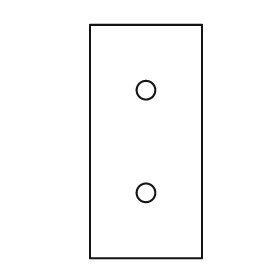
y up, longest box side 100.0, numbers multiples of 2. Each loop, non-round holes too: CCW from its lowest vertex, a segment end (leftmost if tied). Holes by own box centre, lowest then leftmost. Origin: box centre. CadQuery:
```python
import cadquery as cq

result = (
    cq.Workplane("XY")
    .moveTo(-24.0, -50.0)
    .lineTo(24.0, -50.0)
    .lineTo(24.0, 50.0)
    .lineTo(-24.0, 50.0)
    .close()
    .moveTo(0.0, -22.0)
    .circle(4.0)
    .moveTo(0.0, 22.0)
    .circle(4.0)
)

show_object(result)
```